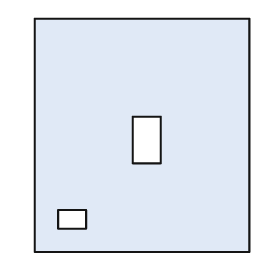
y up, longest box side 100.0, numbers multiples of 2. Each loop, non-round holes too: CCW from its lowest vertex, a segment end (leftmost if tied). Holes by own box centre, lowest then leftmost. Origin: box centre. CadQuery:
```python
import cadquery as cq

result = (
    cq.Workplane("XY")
    .moveTo(-46.0, -50.0)
    .lineTo(46.0, -50.0)
    .lineTo(46.0, 50.0)
    .lineTo(-46.0, 50.0)
    .close()
    .moveTo(-36.0, -40.0)
    .lineTo(-24.0, -40.0)
    .lineTo(-24.0, -32.0)
    .lineTo(-36.0, -32.0)
    .close()
    .moveTo(-4.0, -12.0)
    .lineTo(8.0, -12.0)
    .lineTo(8.0, 8.0)
    .lineTo(-4.0, 8.0)
    .close()
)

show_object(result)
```